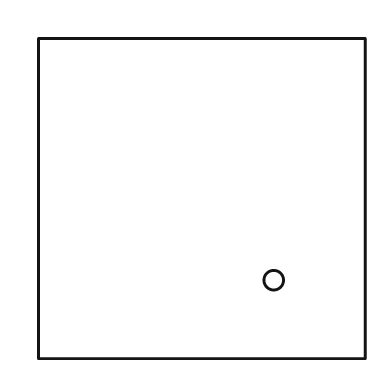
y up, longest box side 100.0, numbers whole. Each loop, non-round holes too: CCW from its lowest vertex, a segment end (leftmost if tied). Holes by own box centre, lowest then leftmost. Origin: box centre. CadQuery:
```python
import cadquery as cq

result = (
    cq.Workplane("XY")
    .moveTo(-50.0, -49.0)
    .lineTo(50.0, -49.0)
    .lineTo(50.0, 49.0)
    .lineTo(-50.0, 49.0)
    .close()
    .moveTo(22.0, -25.0)
    .circle(3.0)
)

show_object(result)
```